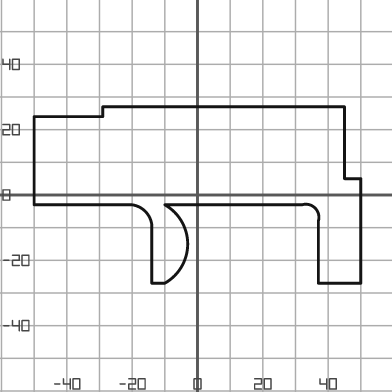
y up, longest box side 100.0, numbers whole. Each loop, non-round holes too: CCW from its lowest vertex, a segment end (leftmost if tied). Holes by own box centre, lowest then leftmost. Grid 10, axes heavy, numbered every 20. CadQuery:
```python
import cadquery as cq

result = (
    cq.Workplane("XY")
    .moveTo(-14.0, -27.0)
    .lineTo(-10.0, -27.0)
    .threePointArc((-3.0, -15.0), (-10.0, -3.0))
    .lineTo(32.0, -3.0)
    .threePointArc((36.0, -4.0), (37.0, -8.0))
    .lineTo(37.0, -27.0)
    .lineTo(50.0, -27.0)
    .lineTo(50.0, 5.0)
    .lineTo(45.0, 5.0)
    .lineTo(45.0, 27.0)
    .lineTo(-29.0, 27.0)
    .lineTo(-29.0, 24.0)
    .lineTo(-50.0, 24.0)
    .lineTo(-50.0, -3.0)
    .lineTo(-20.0, -3.0)
    .threePointArc((-16.0, -5.0), (-14.0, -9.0))
    .close()
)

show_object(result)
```